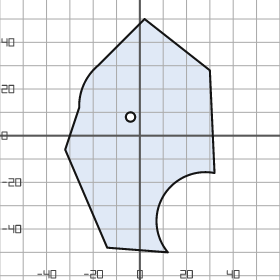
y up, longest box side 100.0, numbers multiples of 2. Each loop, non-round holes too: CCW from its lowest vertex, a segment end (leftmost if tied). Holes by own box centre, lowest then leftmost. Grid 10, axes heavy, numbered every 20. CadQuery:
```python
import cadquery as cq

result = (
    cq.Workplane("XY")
    .moveTo(12.0, -50.0)
    .threePointArc((10.0, -26.0), (32.0, -16.0))
    .lineTo(30.0, 28.0)
    .lineTo(2.0, 50.0)
    .lineTo(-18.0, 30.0)
    .threePointArc((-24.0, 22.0), (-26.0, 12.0))
    .lineTo(-32.0, -6.0)
    .lineTo(-14.0, -48.0)
    .close()
    .moveTo(-4.0, 8.0)
    .circle(2.0)
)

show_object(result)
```